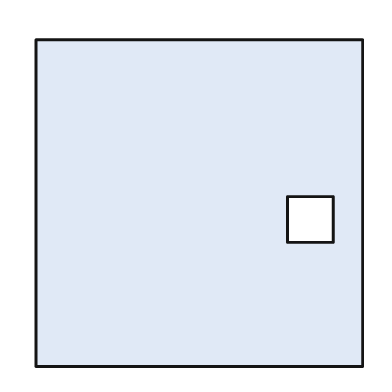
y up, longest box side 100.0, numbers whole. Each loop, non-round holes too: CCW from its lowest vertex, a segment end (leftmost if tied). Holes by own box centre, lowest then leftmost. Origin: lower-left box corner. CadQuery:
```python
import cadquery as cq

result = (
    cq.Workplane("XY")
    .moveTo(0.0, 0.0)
    .lineTo(100.0, 0.0)
    .lineTo(100.0, 100.0)
    .lineTo(0.0, 100.0)
    .close()
    .moveTo(77.0, 38.0)
    .lineTo(91.0, 38.0)
    .lineTo(91.0, 52.0)
    .lineTo(77.0, 52.0)
    .close()
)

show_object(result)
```